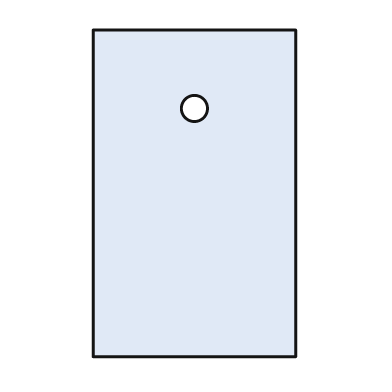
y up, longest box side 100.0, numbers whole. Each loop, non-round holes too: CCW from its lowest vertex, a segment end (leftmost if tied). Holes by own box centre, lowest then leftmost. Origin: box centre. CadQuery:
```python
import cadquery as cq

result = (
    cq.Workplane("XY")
    .moveTo(-31.0, -50.0)
    .lineTo(31.0, -50.0)
    .lineTo(31.0, 50.0)
    .lineTo(-31.0, 50.0)
    .close()
    .moveTo(0.0, 26.0)
    .circle(4.0)
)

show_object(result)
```